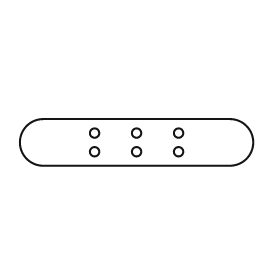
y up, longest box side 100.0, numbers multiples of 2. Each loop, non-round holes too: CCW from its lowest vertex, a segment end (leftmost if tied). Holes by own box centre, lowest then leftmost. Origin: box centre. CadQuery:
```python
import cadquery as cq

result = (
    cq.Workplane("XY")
    .moveTo(-40.0, -10.0)
    .lineTo(40.0, -10.0)
    .threePointArc((50.0, 0.0), (40.0, 10.0))
    .lineTo(-40.0, 10.0)
    .threePointArc((-50.0, 0.0), (-40.0, -10.0))
    .close()
    .moveTo(-18.0, -4.0)
    .circle(2.0)
    .moveTo(0.0, -4.0)
    .circle(2.0)
    .moveTo(18.0, -4.0)
    .circle(2.0)
    .moveTo(-18.0, 4.0)
    .circle(2.0)
    .moveTo(0.0, 4.0)
    .circle(2.0)
    .moveTo(18.0, 4.0)
    .circle(2.0)
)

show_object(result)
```